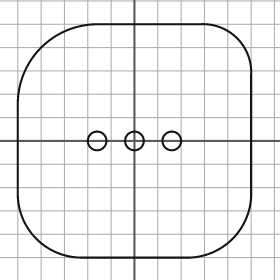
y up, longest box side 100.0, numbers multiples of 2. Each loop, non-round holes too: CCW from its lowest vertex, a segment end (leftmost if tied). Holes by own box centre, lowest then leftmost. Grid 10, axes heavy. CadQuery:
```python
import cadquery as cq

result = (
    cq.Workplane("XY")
    .moveTo(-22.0, -50.0)
    .lineTo(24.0, -50.0)
    .threePointArc((42.0, -42.0), (50.0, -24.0))
    .lineTo(50.0, 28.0)
    .threePointArc((44.0, 44.0), (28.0, 50.0))
    .lineTo(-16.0, 50.0)
    .threePointArc((-40.0, 40.0), (-50.0, 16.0))
    .lineTo(-50.0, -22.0)
    .threePointArc((-42.0, -42.0), (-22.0, -50.0))
    .close()
    .moveTo(-16.0, 0.0)
    .circle(4.0)
    .moveTo(0.0, 0.0)
    .circle(4.0)
    .moveTo(16.0, 0.0)
    .circle(4.0)
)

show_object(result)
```